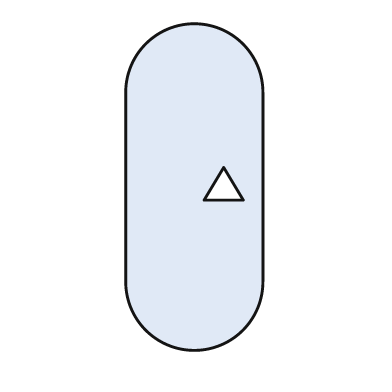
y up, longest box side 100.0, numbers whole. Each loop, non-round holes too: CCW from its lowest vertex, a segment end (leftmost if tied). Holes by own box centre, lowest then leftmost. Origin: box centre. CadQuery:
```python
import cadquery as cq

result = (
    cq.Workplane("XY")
    .moveTo(-21.0, -29.0)
    .threePointArc((0.0, -50.0), (21.0, -29.0))
    .lineTo(21.0, 29.0)
    .threePointArc((0.0, 50.0), (-21.0, 29.0))
    .close()
    .moveTo(3.0, -4.0)
    .lineTo(15.0, -4.0)
    .lineTo(9.0, 6.0)
    .close()
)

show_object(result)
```